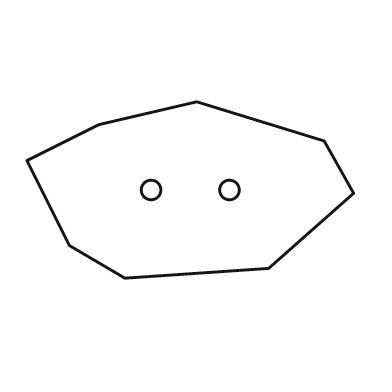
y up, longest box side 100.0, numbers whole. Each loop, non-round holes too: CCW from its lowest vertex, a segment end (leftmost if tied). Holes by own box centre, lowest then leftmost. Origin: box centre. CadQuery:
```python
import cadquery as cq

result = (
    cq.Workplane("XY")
    .moveTo(-20.0, -27.0)
    .lineTo(24.0, -24.0)
    .lineTo(50.0, -1.0)
    .lineTo(41.0, 15.0)
    .lineTo(2.0, 27.0)
    .lineTo(-28.0, 20.0)
    .lineTo(-50.0, 9.0)
    .lineTo(-37.0, -17.0)
    .close()
    .moveTo(-12.0, 0.0)
    .circle(3.0)
    .moveTo(12.0, 0.0)
    .circle(3.0)
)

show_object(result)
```